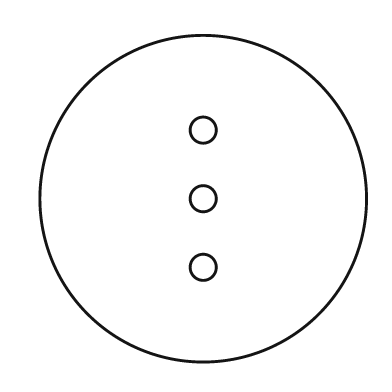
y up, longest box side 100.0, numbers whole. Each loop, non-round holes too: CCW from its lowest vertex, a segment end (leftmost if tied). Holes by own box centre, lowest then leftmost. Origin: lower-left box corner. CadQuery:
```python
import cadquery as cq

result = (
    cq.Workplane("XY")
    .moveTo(50.0, 50.0)
    .circle(50.0)
    .moveTo(50.0, 29.0)
    .circle(4.0)
    .moveTo(50.0, 50.0)
    .circle(4.0)
    .moveTo(50.0, 71.0)
    .circle(4.0)
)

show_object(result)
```